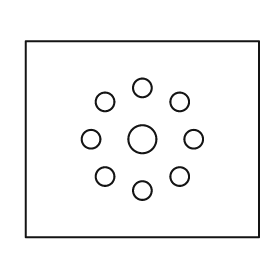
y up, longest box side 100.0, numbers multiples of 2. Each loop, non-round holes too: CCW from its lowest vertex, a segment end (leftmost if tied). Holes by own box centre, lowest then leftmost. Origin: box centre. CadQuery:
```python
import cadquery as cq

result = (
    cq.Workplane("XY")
    .moveTo(-50.0, -42.0)
    .lineTo(50.0, -42.0)
    .lineTo(50.0, 42.0)
    .lineTo(-50.0, 42.0)
    .close()
    .moveTo(0.0, -22.0)
    .circle(4.0)
    .moveTo(-16.0, -16.0)
    .circle(4.0)
    .moveTo(16.0, -16.0)
    .circle(4.0)
    .moveTo(-22.0, 0.0)
    .circle(4.0)
    .moveTo(0.0, 0.0)
    .circle(6.0)
    .moveTo(22.0, 0.0)
    .circle(4.0)
    .moveTo(-16.0, 16.0)
    .circle(4.0)
    .moveTo(16.0, 16.0)
    .circle(4.0)
    .moveTo(0.0, 22.0)
    .circle(4.0)
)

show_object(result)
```